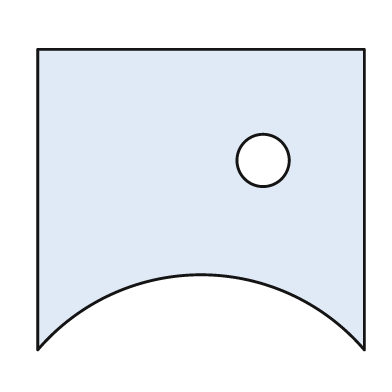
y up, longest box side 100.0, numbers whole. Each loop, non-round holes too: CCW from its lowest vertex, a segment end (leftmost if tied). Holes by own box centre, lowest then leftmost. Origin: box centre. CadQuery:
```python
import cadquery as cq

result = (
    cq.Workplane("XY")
    .moveTo(-50.0, -46.0)
    .threePointArc((0.0, -23.0), (50.0, -46.0))
    .lineTo(50.0, 46.0)
    .lineTo(-50.0, 46.0)
    .close()
    .moveTo(19.0, 12.0)
    .circle(8.0)
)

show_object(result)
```